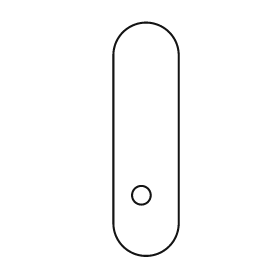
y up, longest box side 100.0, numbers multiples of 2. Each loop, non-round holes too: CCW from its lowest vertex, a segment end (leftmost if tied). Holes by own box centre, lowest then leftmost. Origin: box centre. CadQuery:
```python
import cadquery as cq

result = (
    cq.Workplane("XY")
    .moveTo(-14.0, -36.0)
    .threePointArc((0.0, -50.0), (14.0, -36.0))
    .lineTo(14.0, 36.0)
    .threePointArc((0.0, 50.0), (-14.0, 36.0))
    .close()
    .moveTo(-2.0, -24.0)
    .circle(4.0)
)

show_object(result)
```